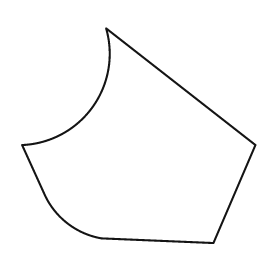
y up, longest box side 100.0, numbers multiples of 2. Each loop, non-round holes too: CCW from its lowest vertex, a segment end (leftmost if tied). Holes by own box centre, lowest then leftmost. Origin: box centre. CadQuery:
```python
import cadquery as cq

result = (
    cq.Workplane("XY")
    .moveTo(32.0, -46.0)
    .lineTo(50.0, -4.0)
    .lineTo(-14.0, 46.0)
    .threePointArc((-20.0, 12.0), (-50.0, -4.0))
    .lineTo(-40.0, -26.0)
    .threePointArc((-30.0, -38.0), (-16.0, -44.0))
    .close()
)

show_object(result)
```